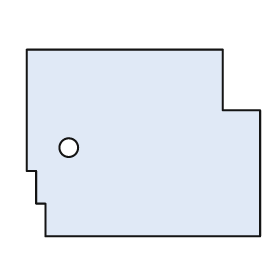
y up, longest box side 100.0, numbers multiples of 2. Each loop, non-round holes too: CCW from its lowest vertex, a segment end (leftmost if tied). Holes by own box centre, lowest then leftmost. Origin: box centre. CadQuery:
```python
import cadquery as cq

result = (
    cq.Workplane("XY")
    .moveTo(-42.0, -40.0)
    .lineTo(50.0, -40.0)
    .lineTo(50.0, 14.0)
    .lineTo(34.0, 14.0)
    .lineTo(34.0, 40.0)
    .lineTo(-50.0, 40.0)
    .lineTo(-50.0, -12.0)
    .lineTo(-46.0, -12.0)
    .lineTo(-46.0, -26.0)
    .lineTo(-42.0, -26.0)
    .close()
    .moveTo(-32.0, -2.0)
    .circle(4.0)
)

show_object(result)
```